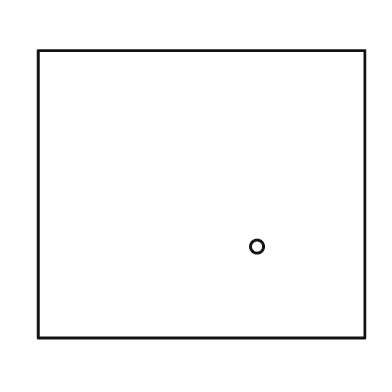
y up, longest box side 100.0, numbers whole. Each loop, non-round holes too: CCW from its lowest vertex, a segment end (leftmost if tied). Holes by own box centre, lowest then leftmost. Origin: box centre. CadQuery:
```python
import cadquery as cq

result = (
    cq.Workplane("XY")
    .moveTo(-50.0, -44.0)
    .lineTo(50.0, -44.0)
    .lineTo(50.0, 44.0)
    .lineTo(-50.0, 44.0)
    .close()
    .moveTo(17.0, -16.0)
    .circle(2.0)
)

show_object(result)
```